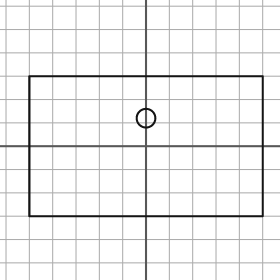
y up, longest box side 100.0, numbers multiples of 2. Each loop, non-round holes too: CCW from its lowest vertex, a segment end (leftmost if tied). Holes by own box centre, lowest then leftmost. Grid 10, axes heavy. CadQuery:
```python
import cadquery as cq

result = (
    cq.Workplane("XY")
    .moveTo(-50.0, -30.0)
    .lineTo(50.0, -30.0)
    .lineTo(50.0, 30.0)
    .lineTo(-50.0, 30.0)
    .close()
    .moveTo(0.0, 12.0)
    .circle(4.0)
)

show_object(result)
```